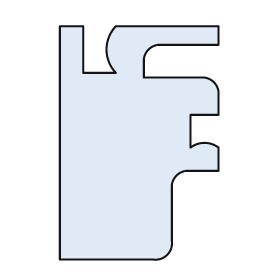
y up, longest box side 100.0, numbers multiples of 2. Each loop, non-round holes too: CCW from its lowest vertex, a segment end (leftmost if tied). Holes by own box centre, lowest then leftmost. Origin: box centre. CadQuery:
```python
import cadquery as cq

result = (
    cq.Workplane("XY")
    .moveTo(-34.0, -50.0)
    .lineTo(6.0, -50.0)
    .threePointArc((12.0, -48.0), (14.0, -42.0))
    .lineTo(14.0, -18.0)
    .threePointArc((16.0, -14.0), (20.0, -12.0))
    .lineTo(34.0, -12.0)
    .lineTo(34.0, -2.0)
    .threePointArc((28.0, 0.0), (22.0, -2.0))
    .lineTo(22.0, 12.0)
    .lineTo(34.0, 12.0)
    .lineTo(34.0, 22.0)
    .threePointArc((32.0, 26.0), (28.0, 28.0))
    .lineTo(2.0, 28.0)
    .lineTo(2.0, 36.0)
    .threePointArc((4.0, 40.0), (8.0, 42.0))
    .lineTo(34.0, 42.0)
    .lineTo(34.0, 50.0)
    .lineTo(-10.0, 50.0)
    .threePointArc((-14.0, 40.0), (-10.0, 30.0))
    .lineTo(-24.0, 30.0)
    .lineTo(-24.0, 50.0)
    .lineTo(-34.0, 50.0)
    .close()
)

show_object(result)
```